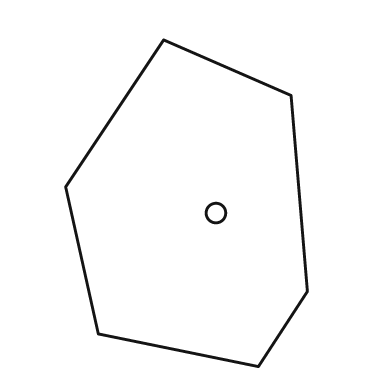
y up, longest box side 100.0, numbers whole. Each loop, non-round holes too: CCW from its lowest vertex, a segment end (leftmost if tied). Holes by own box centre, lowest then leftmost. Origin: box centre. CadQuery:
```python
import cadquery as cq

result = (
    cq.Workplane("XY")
    .moveTo(22.0, -50.0)
    .lineTo(37.0, -27.0)
    .lineTo(32.0, 33.0)
    .lineTo(-7.0, 50.0)
    .lineTo(-37.0, 5.0)
    .lineTo(-27.0, -40.0)
    .close()
    .moveTo(9.0, -3.0)
    .circle(3.0)
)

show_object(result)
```